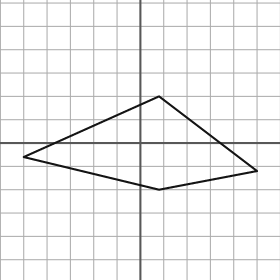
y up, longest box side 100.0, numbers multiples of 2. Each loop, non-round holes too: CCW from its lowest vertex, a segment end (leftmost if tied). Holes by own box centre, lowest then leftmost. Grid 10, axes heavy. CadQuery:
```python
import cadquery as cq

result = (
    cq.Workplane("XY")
    .moveTo(8.0, -20.0)
    .lineTo(50.0, -12.0)
    .lineTo(8.0, 20.0)
    .lineTo(-50.0, -6.0)
    .close()
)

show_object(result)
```